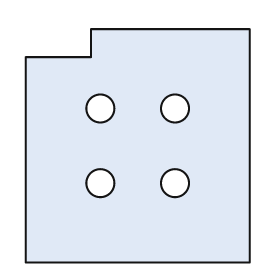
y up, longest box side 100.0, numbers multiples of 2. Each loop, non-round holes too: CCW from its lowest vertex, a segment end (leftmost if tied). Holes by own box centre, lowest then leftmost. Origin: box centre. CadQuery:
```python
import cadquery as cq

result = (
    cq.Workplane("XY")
    .moveTo(-48.0, -50.0)
    .lineTo(48.0, -50.0)
    .lineTo(48.0, 50.0)
    .lineTo(-20.0, 50.0)
    .lineTo(-20.0, 38.0)
    .lineTo(-48.0, 38.0)
    .close()
    .moveTo(-16.0, -16.0)
    .circle(6.0)
    .moveTo(16.0, -16.0)
    .circle(6.0)
    .moveTo(-16.0, 16.0)
    .circle(6.0)
    .moveTo(16.0, 16.0)
    .circle(6.0)
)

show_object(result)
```